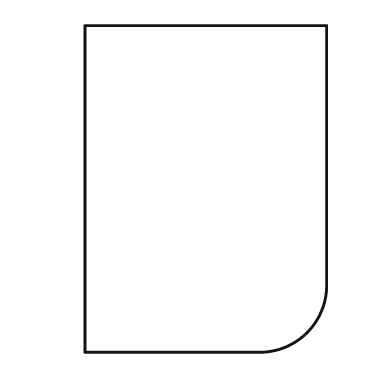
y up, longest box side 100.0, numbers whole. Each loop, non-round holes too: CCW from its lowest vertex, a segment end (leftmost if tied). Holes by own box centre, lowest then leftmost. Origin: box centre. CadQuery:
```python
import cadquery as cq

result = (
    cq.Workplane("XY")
    .moveTo(-37.0, -50.0)
    .lineTo(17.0, -50.0)
    .threePointArc((31.0, -44.0), (37.0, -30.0))
    .lineTo(37.0, 50.0)
    .lineTo(-37.0, 50.0)
    .close()
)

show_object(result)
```